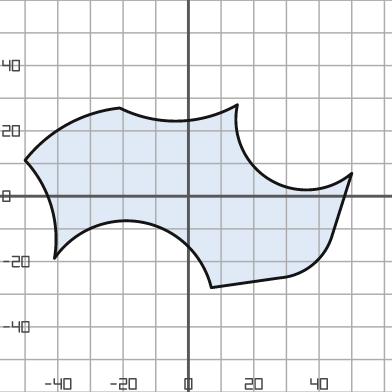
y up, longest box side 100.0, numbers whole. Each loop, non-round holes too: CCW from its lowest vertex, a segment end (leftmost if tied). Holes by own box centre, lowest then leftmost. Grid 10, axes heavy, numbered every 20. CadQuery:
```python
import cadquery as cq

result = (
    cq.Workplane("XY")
    .moveTo(7.0, -28.0)
    .lineTo(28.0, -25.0)
    .threePointArc((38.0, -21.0), (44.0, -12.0))
    .lineTo(50.0, 7.0)
    .threePointArc((25.0, 5.0), (15.0, 28.0))
    .threePointArc((-3.0, 23.0), (-21.0, 27.0))
    .threePointArc((-37.0, 22.0), (-50.0, 11.0))
    .threePointArc((-42.0, -3.0), (-41.0, -19.0))
    .threePointArc((-14.0, -8.0), (7.0, -28.0))
    .close()
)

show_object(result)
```